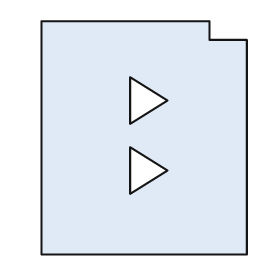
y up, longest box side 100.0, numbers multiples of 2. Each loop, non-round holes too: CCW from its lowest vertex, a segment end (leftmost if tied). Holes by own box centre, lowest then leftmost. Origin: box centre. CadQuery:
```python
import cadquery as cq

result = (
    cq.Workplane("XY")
    .moveTo(-44.0, -50.0)
    .lineTo(44.0, -50.0)
    .lineTo(44.0, 42.0)
    .lineTo(28.0, 42.0)
    .lineTo(28.0, 50.0)
    .lineTo(-44.0, 50.0)
    .close()
    .moveTo(-6.0, -24.0)
    .lineTo(10.0, -14.0)
    .lineTo(-6.0, -4.0)
    .close()
    .moveTo(-6.0, 6.0)
    .lineTo(10.0, 16.0)
    .lineTo(-6.0, 26.0)
    .close()
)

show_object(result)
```